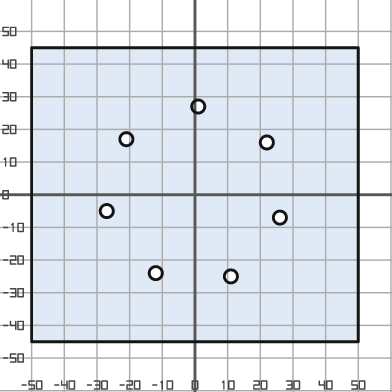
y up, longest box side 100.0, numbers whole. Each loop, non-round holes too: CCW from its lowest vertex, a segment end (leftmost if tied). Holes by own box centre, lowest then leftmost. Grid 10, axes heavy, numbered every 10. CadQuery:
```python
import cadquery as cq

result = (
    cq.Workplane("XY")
    .moveTo(-50.0, -45.0)
    .lineTo(50.0, -45.0)
    .lineTo(50.0, 45.0)
    .lineTo(-50.0, 45.0)
    .close()
    .moveTo(11.0, -25.0)
    .circle(2.0)
    .moveTo(-12.0, -24.0)
    .circle(2.0)
    .moveTo(26.0, -7.0)
    .circle(2.0)
    .moveTo(-27.0, -5.0)
    .circle(2.0)
    .moveTo(22.0, 16.0)
    .circle(2.0)
    .moveTo(-21.0, 17.0)
    .circle(2.0)
    .moveTo(1.0, 27.0)
    .circle(2.0)
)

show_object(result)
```